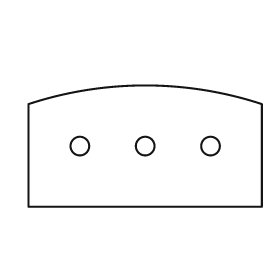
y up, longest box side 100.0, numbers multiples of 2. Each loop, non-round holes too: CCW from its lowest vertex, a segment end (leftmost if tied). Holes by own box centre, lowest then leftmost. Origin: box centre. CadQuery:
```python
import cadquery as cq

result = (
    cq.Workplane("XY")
    .moveTo(-50.0, -26.0)
    .lineTo(50.0, -26.0)
    .lineTo(50.0, 18.0)
    .threePointArc((0.0, 26.0), (-50.0, 18.0))
    .close()
    .moveTo(-28.0, 0.0)
    .circle(4.0)
    .moveTo(0.0, 0.0)
    .circle(4.0)
    .moveTo(28.0, 0.0)
    .circle(4.0)
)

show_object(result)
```